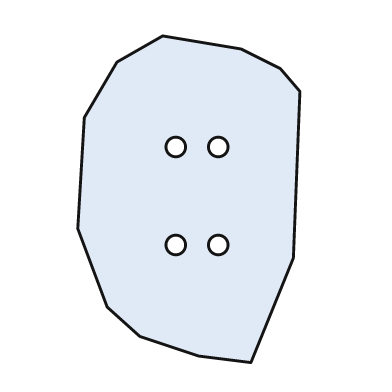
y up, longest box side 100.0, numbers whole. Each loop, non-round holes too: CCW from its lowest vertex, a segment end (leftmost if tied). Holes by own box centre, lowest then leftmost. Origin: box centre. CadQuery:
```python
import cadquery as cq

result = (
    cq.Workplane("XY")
    .moveTo(19.0, -50.0)
    .lineTo(32.0, -18.0)
    .lineTo(34.0, 33.0)
    .lineTo(28.0, 40.0)
    .lineTo(16.0, 46.0)
    .lineTo(-8.0, 50.0)
    .lineTo(-22.0, 42.0)
    .lineTo(-32.0, 25.0)
    .lineTo(-34.0, -9.0)
    .lineTo(-25.0, -33.0)
    .lineTo(-15.0, -42.0)
    .lineTo(3.0, -48.0)
    .close()
    .moveTo(-4.0, -14.0)
    .circle(3.0)
    .moveTo(9.0, -14.0)
    .circle(3.0)
    .moveTo(-4.0, 16.0)
    .circle(3.0)
    .moveTo(9.0, 16.0)
    .circle(3.0)
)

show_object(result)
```